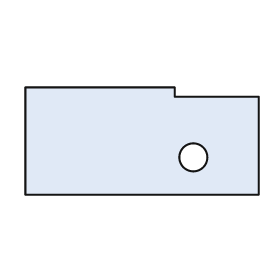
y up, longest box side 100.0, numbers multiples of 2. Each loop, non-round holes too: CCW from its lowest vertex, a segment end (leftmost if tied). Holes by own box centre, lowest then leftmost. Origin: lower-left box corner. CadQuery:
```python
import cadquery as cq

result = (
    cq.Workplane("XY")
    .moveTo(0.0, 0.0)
    .lineTo(100.0, 0.0)
    .lineTo(100.0, 42.0)
    .lineTo(64.0, 42.0)
    .lineTo(64.0, 46.0)
    .lineTo(0.0, 46.0)
    .close()
    .moveTo(72.0, 16.0)
    .circle(6.0)
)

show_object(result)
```